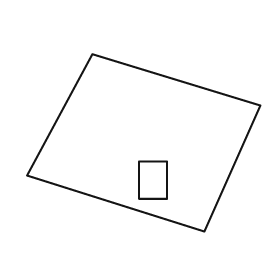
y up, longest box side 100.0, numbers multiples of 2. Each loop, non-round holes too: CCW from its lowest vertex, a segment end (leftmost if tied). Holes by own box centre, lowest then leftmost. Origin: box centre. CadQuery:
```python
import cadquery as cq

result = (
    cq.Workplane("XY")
    .moveTo(26.0, -38.0)
    .lineTo(50.0, 16.0)
    .lineTo(-22.0, 38.0)
    .lineTo(-50.0, -14.0)
    .close()
    .moveTo(-2.0, -24.0)
    .lineTo(10.0, -24.0)
    .lineTo(10.0, -8.0)
    .lineTo(-2.0, -8.0)
    .close()
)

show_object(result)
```